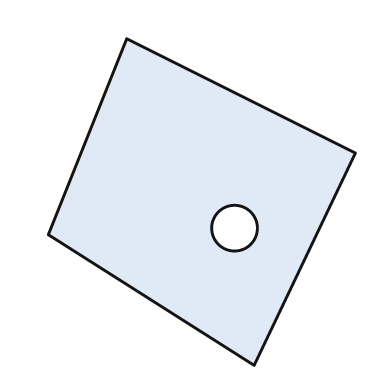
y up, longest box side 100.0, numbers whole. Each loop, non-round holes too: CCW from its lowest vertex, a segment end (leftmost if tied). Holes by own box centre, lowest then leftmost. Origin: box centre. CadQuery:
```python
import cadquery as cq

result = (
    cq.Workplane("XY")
    .moveTo(16.0, -50.0)
    .lineTo(47.0, 15.0)
    .lineTo(-23.0, 50.0)
    .lineTo(-47.0, -10.0)
    .close()
    .moveTo(10.0, -8.0)
    .circle(7.0)
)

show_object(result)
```